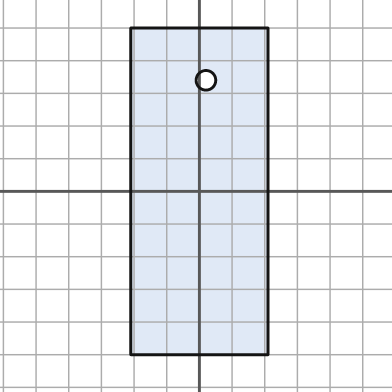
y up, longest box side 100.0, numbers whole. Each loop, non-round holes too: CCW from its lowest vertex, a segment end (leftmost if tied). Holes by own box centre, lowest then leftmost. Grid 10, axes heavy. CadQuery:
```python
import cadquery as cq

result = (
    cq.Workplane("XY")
    .moveTo(-21.0, -50.0)
    .lineTo(21.0, -50.0)
    .lineTo(21.0, 50.0)
    .lineTo(-21.0, 50.0)
    .close()
    .moveTo(2.0, 34.0)
    .circle(3.0)
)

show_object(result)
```